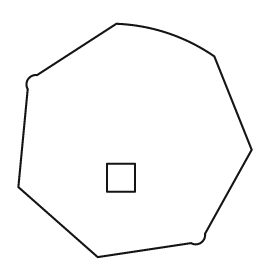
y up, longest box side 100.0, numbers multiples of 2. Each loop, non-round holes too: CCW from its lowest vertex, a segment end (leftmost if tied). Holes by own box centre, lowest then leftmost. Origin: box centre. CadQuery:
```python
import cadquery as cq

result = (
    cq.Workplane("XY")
    .moveTo(-16.0, -50.0)
    .lineTo(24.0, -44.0)
    .threePointArc((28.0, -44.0), (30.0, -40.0))
    .lineTo(50.0, -4.0)
    .lineTo(34.0, 36.0)
    .threePointArc((14.0, 46.0), (-8.0, 50.0))
    .lineTo(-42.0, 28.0)
    .threePointArc((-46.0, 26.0), (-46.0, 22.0))
    .lineTo(-50.0, -20.0)
    .close()
    .moveTo(-12.0, -22.0)
    .lineTo(0.0, -22.0)
    .lineTo(0.0, -10.0)
    .lineTo(-12.0, -10.0)
    .close()
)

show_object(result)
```